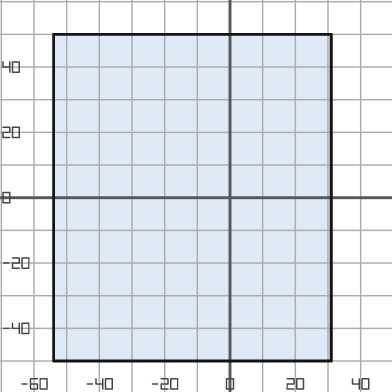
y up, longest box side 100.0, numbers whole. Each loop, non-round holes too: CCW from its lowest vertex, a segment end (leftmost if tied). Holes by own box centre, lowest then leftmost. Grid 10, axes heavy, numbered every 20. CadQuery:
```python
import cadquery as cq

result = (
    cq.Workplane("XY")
    .moveTo(-54.0, -50.0)
    .lineTo(31.0, -50.0)
    .lineTo(31.0, 50.0)
    .lineTo(-54.0, 50.0)
    .close()
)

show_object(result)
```